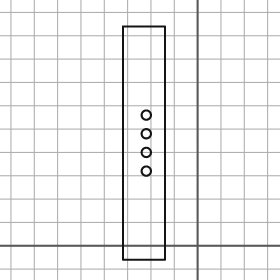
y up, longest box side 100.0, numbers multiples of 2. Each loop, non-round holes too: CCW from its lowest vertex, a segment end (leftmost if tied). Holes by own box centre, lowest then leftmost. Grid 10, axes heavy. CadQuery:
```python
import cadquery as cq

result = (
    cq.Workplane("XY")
    .moveTo(-32.0, -6.0)
    .lineTo(-14.0, -6.0)
    .lineTo(-14.0, 94.0)
    .lineTo(-32.0, 94.0)
    .close()
    .moveTo(-22.0, 32.0)
    .circle(2.0)
    .moveTo(-22.0, 40.0)
    .circle(2.0)
    .moveTo(-22.0, 48.0)
    .circle(2.0)
    .moveTo(-22.0, 56.0)
    .circle(2.0)
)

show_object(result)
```